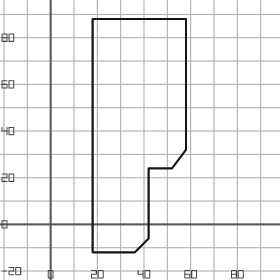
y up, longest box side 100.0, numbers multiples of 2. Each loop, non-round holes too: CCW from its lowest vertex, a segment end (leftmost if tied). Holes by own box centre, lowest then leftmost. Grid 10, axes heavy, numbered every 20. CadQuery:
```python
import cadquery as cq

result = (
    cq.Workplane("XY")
    .moveTo(18.0, -12.0)
    .lineTo(36.0, -12.0)
    .lineTo(42.0, -6.0)
    .lineTo(42.0, 24.0)
    .lineTo(52.0, 24.0)
    .lineTo(58.0, 32.0)
    .lineTo(58.0, 88.0)
    .lineTo(18.0, 88.0)
    .close()
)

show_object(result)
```